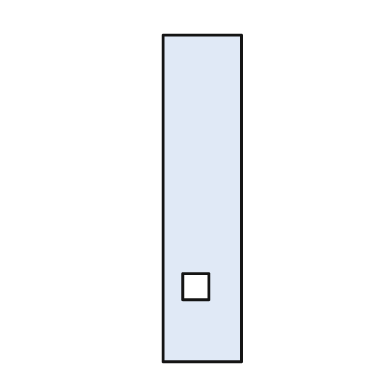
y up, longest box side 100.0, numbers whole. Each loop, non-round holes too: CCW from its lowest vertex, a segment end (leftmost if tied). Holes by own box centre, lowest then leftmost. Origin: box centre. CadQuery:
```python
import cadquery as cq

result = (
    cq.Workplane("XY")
    .moveTo(-12.0, -50.0)
    .lineTo(12.0, -50.0)
    .lineTo(12.0, 50.0)
    .lineTo(-12.0, 50.0)
    .close()
    .moveTo(-6.0, -31.0)
    .lineTo(2.0, -31.0)
    .lineTo(2.0, -23.0)
    .lineTo(-6.0, -23.0)
    .close()
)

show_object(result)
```